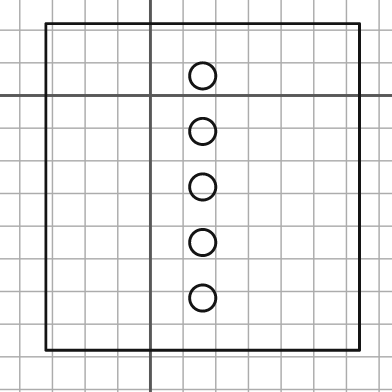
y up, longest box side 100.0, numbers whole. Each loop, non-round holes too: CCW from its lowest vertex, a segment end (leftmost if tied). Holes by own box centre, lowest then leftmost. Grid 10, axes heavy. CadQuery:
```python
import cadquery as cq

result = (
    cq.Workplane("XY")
    .moveTo(-32.0, -78.0)
    .lineTo(64.0, -78.0)
    .lineTo(64.0, 22.0)
    .lineTo(-32.0, 22.0)
    .close()
    .moveTo(16.0, -62.0)
    .circle(4.0)
    .moveTo(16.0, -45.0)
    .circle(4.0)
    .moveTo(16.0, -28.0)
    .circle(4.0)
    .moveTo(16.0, -11.0)
    .circle(4.0)
    .moveTo(16.0, 6.0)
    .circle(4.0)
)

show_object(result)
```